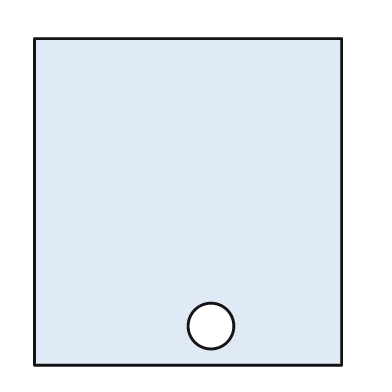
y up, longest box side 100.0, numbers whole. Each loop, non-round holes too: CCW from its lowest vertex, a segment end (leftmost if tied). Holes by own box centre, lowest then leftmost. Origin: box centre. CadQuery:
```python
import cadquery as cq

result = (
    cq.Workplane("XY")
    .moveTo(-47.0, -50.0)
    .lineTo(47.0, -50.0)
    .lineTo(47.0, 50.0)
    .lineTo(-47.0, 50.0)
    .close()
    .moveTo(7.0, -38.0)
    .circle(7.0)
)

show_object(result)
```